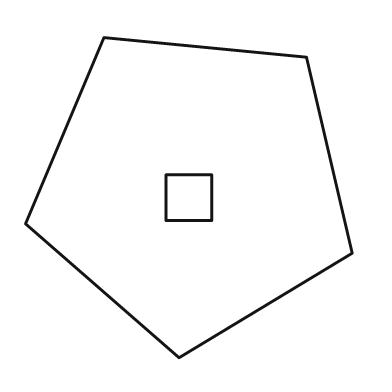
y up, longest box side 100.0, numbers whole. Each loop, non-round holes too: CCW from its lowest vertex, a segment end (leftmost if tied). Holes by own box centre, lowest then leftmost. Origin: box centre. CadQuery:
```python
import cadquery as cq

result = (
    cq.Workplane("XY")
    .moveTo(-3.0, -49.0)
    .lineTo(50.0, -17.0)
    .lineTo(36.0, 43.0)
    .lineTo(-26.0, 49.0)
    .lineTo(-50.0, -8.0)
    .close()
    .moveTo(-7.0, -7.0)
    .lineTo(7.0, -7.0)
    .lineTo(7.0, 7.0)
    .lineTo(-7.0, 7.0)
    .close()
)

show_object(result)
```